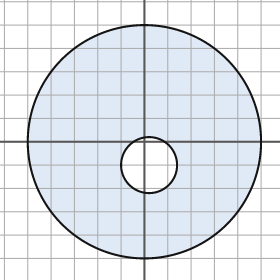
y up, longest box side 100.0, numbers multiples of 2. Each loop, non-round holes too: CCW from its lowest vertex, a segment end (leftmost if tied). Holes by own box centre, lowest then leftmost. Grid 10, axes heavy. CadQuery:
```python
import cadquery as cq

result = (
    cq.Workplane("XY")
    .moveTo(0.0, 0.0)
    .circle(50.0)
    .moveTo(2.0, -10.0)
    .circle(12.0)
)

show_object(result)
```